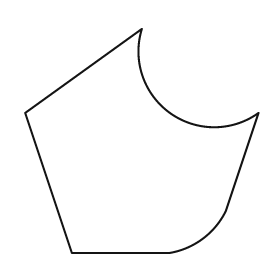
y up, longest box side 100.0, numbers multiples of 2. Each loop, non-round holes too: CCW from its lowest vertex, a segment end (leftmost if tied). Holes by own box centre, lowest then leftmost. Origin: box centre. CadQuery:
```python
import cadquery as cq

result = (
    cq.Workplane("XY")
    .moveTo(-30.0, -48.0)
    .lineTo(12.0, -48.0)
    .threePointArc((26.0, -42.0), (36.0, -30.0))
    .lineTo(50.0, 12.0)
    .threePointArc((12.0, 12.0), (0.0, 48.0))
    .lineTo(-50.0, 12.0)
    .close()
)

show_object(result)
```